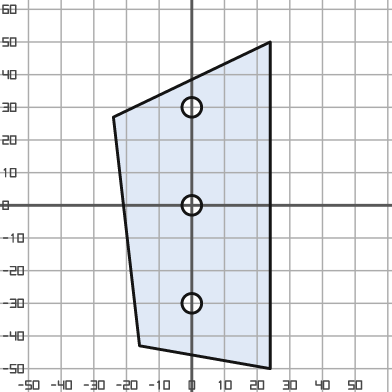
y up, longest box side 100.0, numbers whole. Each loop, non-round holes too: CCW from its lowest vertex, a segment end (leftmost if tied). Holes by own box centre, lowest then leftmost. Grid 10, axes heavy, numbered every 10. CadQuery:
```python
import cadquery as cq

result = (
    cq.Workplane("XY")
    .moveTo(24.0, -50.0)
    .lineTo(24.0, 50.0)
    .lineTo(-24.0, 27.0)
    .lineTo(-16.0, -43.0)
    .close()
    .moveTo(0.0, -30.0)
    .circle(3.0)
    .moveTo(0.0, 0.0)
    .circle(3.0)
    .moveTo(0.0, 30.0)
    .circle(3.0)
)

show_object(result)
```